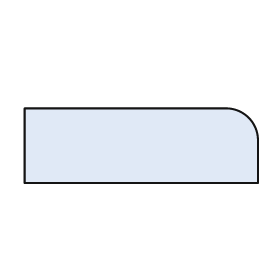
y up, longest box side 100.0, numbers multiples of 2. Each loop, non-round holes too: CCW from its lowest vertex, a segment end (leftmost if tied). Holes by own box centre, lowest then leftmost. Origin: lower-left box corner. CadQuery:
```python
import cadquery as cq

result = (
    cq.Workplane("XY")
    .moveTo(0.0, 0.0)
    .lineTo(100.0, 0.0)
    .lineTo(100.0, 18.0)
    .threePointArc((96.0, 28.0), (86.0, 32.0))
    .lineTo(0.0, 32.0)
    .close()
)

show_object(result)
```